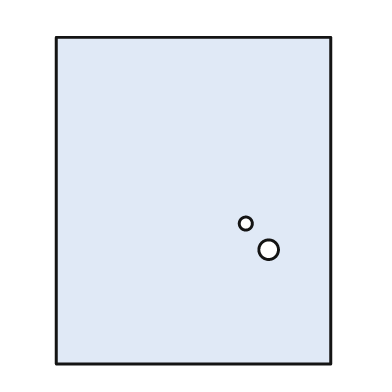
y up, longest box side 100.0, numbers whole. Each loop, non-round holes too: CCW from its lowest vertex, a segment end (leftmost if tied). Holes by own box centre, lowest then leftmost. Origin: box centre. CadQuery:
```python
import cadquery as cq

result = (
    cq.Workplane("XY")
    .moveTo(-42.0, -50.0)
    .lineTo(42.0, -50.0)
    .lineTo(42.0, 50.0)
    .lineTo(-42.0, 50.0)
    .close()
    .moveTo(23.0, -15.0)
    .circle(3.0)
    .moveTo(16.0, -7.0)
    .circle(2.0)
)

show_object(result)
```